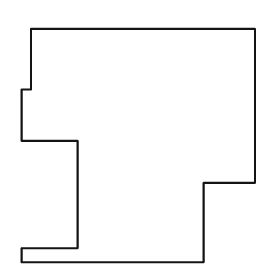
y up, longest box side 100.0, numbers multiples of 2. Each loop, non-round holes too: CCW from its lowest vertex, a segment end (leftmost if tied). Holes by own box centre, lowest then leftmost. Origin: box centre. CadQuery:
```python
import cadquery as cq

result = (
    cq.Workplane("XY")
    .moveTo(-50.0, -50.0)
    .lineTo(28.0, -50.0)
    .lineTo(28.0, -16.0)
    .lineTo(50.0, -16.0)
    .lineTo(50.0, 50.0)
    .lineTo(-46.0, 50.0)
    .lineTo(-46.0, 24.0)
    .lineTo(-50.0, 24.0)
    .lineTo(-50.0, 2.0)
    .lineTo(-26.0, 2.0)
    .lineTo(-26.0, -44.0)
    .lineTo(-50.0, -44.0)
    .close()
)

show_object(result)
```